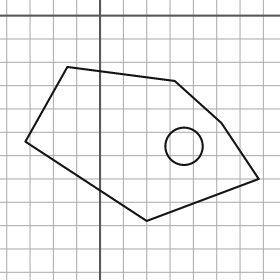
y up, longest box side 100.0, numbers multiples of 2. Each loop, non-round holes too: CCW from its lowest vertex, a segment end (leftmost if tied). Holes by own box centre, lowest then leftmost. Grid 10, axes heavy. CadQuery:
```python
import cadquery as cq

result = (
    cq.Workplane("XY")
    .moveTo(20.0, -88.0)
    .lineTo(68.0, -70.0)
    .lineTo(52.0, -46.0)
    .lineTo(32.0, -28.0)
    .lineTo(-14.0, -22.0)
    .lineTo(-32.0, -54.0)
    .close()
    .moveTo(36.0, -56.0)
    .circle(8.0)
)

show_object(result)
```